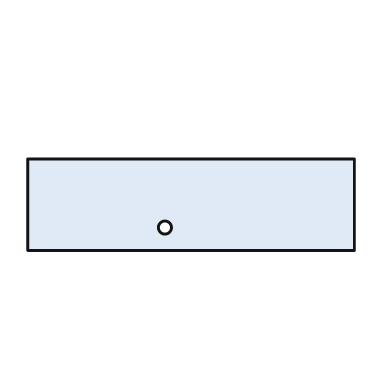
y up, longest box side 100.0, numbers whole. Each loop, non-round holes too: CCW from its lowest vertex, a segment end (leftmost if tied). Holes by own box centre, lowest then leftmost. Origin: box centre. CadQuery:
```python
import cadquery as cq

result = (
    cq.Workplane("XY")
    .moveTo(-50.0, -14.0)
    .lineTo(50.0, -14.0)
    .lineTo(50.0, 14.0)
    .lineTo(-50.0, 14.0)
    .close()
    .moveTo(-8.0, -7.0)
    .circle(2.0)
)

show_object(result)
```